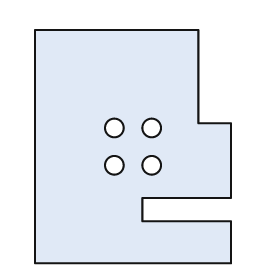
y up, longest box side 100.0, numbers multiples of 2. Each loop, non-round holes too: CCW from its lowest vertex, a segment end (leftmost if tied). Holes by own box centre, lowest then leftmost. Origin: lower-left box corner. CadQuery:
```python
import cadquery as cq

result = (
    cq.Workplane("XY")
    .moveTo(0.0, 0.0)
    .lineTo(84.0, 0.0)
    .lineTo(84.0, 18.0)
    .lineTo(46.0, 18.0)
    .lineTo(46.0, 28.0)
    .lineTo(84.0, 28.0)
    .lineTo(84.0, 60.0)
    .lineTo(70.0, 60.0)
    .lineTo(70.0, 100.0)
    .lineTo(0.0, 100.0)
    .close()
    .moveTo(34.0, 42.0)
    .circle(4.0)
    .moveTo(50.0, 42.0)
    .circle(4.0)
    .moveTo(34.0, 58.0)
    .circle(4.0)
    .moveTo(50.0, 58.0)
    .circle(4.0)
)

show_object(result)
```